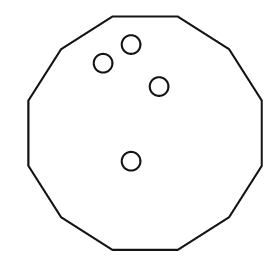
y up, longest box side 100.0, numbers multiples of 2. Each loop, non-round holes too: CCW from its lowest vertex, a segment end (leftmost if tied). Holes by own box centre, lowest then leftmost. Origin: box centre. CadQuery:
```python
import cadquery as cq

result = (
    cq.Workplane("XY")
    .moveTo(-14.0, -50.0)
    .lineTo(14.0, -50.0)
    .lineTo(36.0, -36.0)
    .lineTo(50.0, -14.0)
    .lineTo(50.0, 14.0)
    .lineTo(36.0, 36.0)
    .lineTo(14.0, 50.0)
    .lineTo(-14.0, 50.0)
    .lineTo(-36.0, 36.0)
    .lineTo(-50.0, 14.0)
    .lineTo(-50.0, -14.0)
    .lineTo(-36.0, -36.0)
    .close()
    .moveTo(-6.0, -12.0)
    .circle(4.0)
    .moveTo(6.0, 20.0)
    .circle(4.0)
    .moveTo(-18.0, 30.0)
    .circle(4.0)
    .moveTo(-6.0, 38.0)
    .circle(4.0)
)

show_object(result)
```